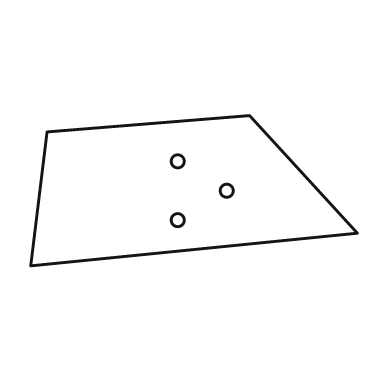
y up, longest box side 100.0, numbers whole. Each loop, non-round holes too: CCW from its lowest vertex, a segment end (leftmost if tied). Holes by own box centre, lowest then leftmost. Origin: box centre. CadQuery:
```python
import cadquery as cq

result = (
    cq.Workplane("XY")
    .moveTo(-50.0, -23.0)
    .lineTo(50.0, -13.0)
    .lineTo(17.0, 23.0)
    .lineTo(-45.0, 18.0)
    .close()
    .moveTo(-5.0, -9.0)
    .circle(2.0)
    .moveTo(10.0, 0.0)
    .circle(2.0)
    .moveTo(-5.0, 9.0)
    .circle(2.0)
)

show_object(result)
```